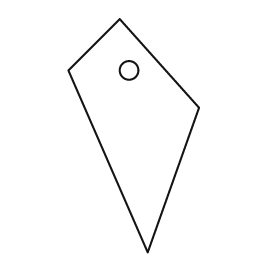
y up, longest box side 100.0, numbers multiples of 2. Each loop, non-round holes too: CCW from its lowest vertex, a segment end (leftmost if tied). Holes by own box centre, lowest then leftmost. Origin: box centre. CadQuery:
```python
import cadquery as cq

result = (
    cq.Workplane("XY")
    .moveTo(6.0, -50.0)
    .lineTo(28.0, 12.0)
    .lineTo(-6.0, 50.0)
    .lineTo(-28.0, 28.0)
    .close()
    .moveTo(-2.0, 28.0)
    .circle(4.0)
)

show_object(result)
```